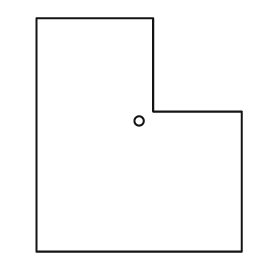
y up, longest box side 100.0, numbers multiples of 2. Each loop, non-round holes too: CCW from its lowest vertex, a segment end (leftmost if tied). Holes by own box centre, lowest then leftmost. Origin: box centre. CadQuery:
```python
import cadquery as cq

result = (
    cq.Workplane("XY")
    .moveTo(-44.0, -50.0)
    .lineTo(44.0, -50.0)
    .lineTo(44.0, 10.0)
    .lineTo(6.0, 10.0)
    .lineTo(6.0, 50.0)
    .lineTo(-44.0, 50.0)
    .close()
    .moveTo(0.0, 6.0)
    .circle(2.0)
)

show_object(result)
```